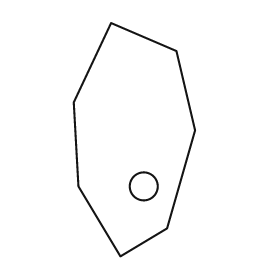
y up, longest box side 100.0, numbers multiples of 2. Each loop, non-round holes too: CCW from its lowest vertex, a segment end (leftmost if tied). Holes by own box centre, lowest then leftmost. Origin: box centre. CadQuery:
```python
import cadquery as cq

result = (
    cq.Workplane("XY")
    .moveTo(-6.0, -50.0)
    .lineTo(14.0, -38.0)
    .lineTo(26.0, 4.0)
    .lineTo(18.0, 38.0)
    .lineTo(-10.0, 50.0)
    .lineTo(-26.0, 16.0)
    .lineTo(-24.0, -20.0)
    .close()
    .moveTo(4.0, -20.0)
    .circle(6.0)
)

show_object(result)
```